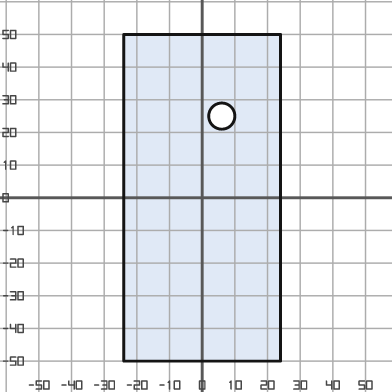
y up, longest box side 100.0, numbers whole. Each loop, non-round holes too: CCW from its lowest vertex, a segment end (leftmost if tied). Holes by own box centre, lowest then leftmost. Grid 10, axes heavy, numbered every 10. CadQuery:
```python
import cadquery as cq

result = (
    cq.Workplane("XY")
    .moveTo(-24.0, -50.0)
    .lineTo(24.0, -50.0)
    .lineTo(24.0, 50.0)
    .lineTo(-24.0, 50.0)
    .close()
    .moveTo(6.0, 25.0)
    .circle(4.0)
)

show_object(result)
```